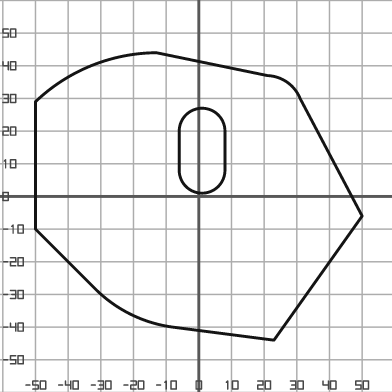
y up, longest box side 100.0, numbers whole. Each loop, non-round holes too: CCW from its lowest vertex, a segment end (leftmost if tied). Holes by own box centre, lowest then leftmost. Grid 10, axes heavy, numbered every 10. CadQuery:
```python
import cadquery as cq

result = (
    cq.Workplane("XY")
    .moveTo(23.0, -44.0)
    .lineTo(50.0, -6.0)
    .lineTo(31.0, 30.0)
    .threePointArc((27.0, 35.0), (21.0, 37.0))
    .lineTo(-13.0, 44.0)
    .threePointArc((-33.0, 40.0), (-50.0, 29.0))
    .lineTo(-50.0, -10.0)
    .lineTo(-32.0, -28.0)
    .threePointArc((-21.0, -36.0), (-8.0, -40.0))
    .close()
    .moveTo(-6.0, 8.0)
    .threePointArc((1.0, 1.0), (8.0, 8.0))
    .lineTo(8.0, 20.0)
    .threePointArc((1.0, 27.0), (-6.0, 20.0))
    .close()
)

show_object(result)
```